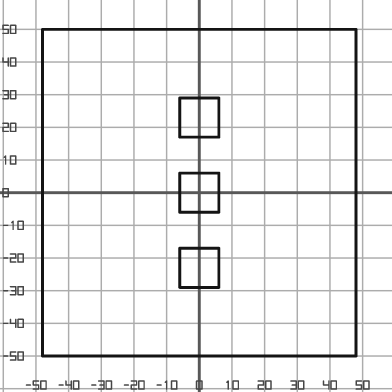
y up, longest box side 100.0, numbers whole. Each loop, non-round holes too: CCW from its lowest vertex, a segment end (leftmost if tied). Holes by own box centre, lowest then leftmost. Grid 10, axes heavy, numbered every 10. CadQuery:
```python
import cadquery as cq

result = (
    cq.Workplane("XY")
    .moveTo(-48.0, -50.0)
    .lineTo(48.0, -50.0)
    .lineTo(48.0, 50.0)
    .lineTo(-48.0, 50.0)
    .close()
    .moveTo(-6.0, -29.0)
    .lineTo(6.0, -29.0)
    .lineTo(6.0, -17.0)
    .lineTo(-6.0, -17.0)
    .close()
    .moveTo(-6.0, -6.0)
    .lineTo(6.0, -6.0)
    .lineTo(6.0, 6.0)
    .lineTo(-6.0, 6.0)
    .close()
    .moveTo(-6.0, 17.0)
    .lineTo(6.0, 17.0)
    .lineTo(6.0, 29.0)
    .lineTo(-6.0, 29.0)
    .close()
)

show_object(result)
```